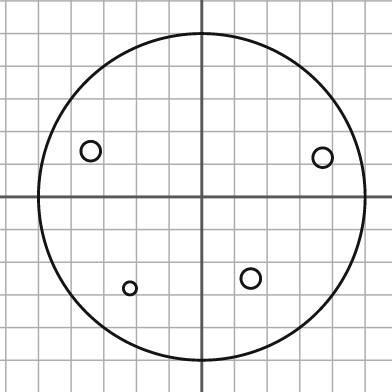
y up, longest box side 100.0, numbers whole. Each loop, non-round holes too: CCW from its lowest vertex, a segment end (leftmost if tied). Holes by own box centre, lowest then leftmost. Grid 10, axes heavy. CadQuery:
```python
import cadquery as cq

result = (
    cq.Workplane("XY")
    .moveTo(0.0, 0.0)
    .circle(50.0)
    .moveTo(-22.0, -28.0)
    .circle(2.0)
    .moveTo(15.0, -25.0)
    .circle(3.0)
    .moveTo(37.0, 12.0)
    .circle(3.0)
    .moveTo(-34.0, 14.0)
    .circle(3.0)
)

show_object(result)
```